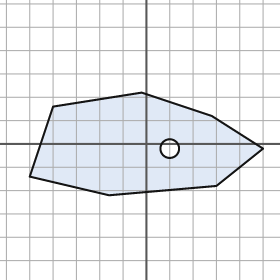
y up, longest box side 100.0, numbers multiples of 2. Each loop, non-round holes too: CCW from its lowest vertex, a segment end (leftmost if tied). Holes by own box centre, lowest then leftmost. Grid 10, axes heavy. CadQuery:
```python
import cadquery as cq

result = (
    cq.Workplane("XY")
    .moveTo(-16.0, -22.0)
    .lineTo(30.0, -18.0)
    .lineTo(50.0, -2.0)
    .lineTo(28.0, 12.0)
    .lineTo(-2.0, 22.0)
    .lineTo(-40.0, 16.0)
    .lineTo(-50.0, -14.0)
    .close()
    .moveTo(10.0, -2.0)
    .circle(4.0)
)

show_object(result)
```